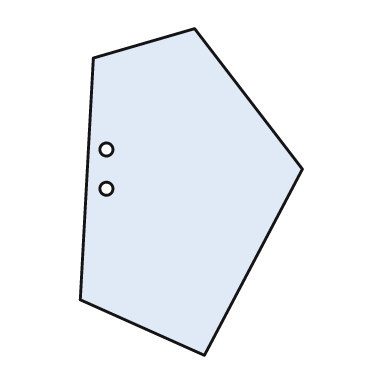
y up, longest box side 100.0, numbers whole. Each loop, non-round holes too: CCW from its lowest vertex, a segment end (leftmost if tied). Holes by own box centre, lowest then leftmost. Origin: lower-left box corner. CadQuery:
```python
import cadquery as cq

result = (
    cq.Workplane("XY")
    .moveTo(38.0, 0.0)
    .lineTo(68.0, 57.0)
    .lineTo(35.0, 100.0)
    .lineTo(4.0, 91.0)
    .lineTo(0.0, 17.0)
    .close()
    .moveTo(8.0, 51.0)
    .circle(2.0)
    .moveTo(8.0, 63.0)
    .circle(2.0)
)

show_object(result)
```